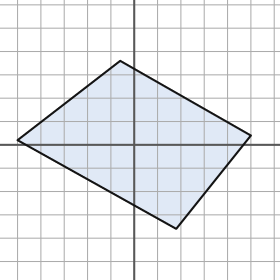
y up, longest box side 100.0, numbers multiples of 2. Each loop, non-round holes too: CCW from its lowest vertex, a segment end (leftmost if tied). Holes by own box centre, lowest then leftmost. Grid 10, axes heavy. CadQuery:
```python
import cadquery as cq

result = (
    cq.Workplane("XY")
    .moveTo(18.0, -36.0)
    .lineTo(50.0, 4.0)
    .lineTo(-6.0, 36.0)
    .lineTo(-50.0, 2.0)
    .close()
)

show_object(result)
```